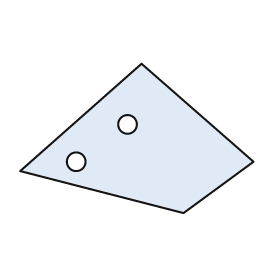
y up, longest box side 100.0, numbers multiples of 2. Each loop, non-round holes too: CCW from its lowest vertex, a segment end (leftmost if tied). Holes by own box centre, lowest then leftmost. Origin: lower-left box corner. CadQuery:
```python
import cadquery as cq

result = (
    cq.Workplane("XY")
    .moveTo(70.0, 0.0)
    .lineTo(100.0, 22.0)
    .lineTo(52.0, 64.0)
    .lineTo(0.0, 18.0)
    .close()
    .moveTo(24.0, 22.0)
    .circle(4.0)
    .moveTo(46.0, 38.0)
    .circle(4.0)
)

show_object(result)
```